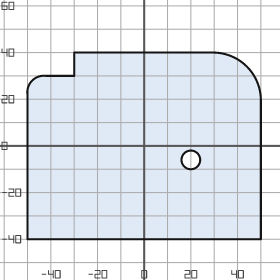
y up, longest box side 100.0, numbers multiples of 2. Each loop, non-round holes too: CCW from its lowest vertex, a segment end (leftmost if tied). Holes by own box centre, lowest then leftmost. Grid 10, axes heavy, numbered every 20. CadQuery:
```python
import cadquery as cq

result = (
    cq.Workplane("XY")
    .moveTo(-50.0, -40.0)
    .lineTo(50.0, -40.0)
    .lineTo(50.0, 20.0)
    .threePointArc((44.0, 34.0), (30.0, 40.0))
    .lineTo(-30.0, 40.0)
    .lineTo(-30.0, 30.0)
    .lineTo(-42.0, 30.0)
    .threePointArc((-48.0, 28.0), (-50.0, 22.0))
    .close()
    .moveTo(20.0, -6.0)
    .circle(4.0)
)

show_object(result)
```